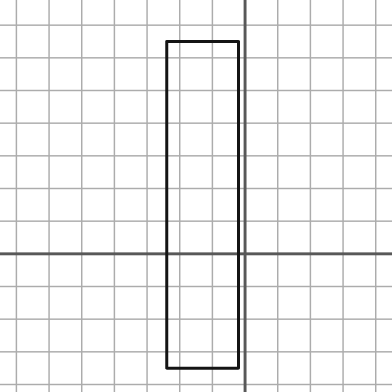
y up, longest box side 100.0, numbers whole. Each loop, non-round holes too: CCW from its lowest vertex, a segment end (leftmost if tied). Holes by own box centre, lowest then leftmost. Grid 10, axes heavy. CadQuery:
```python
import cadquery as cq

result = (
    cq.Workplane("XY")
    .moveTo(-24.0, -35.0)
    .lineTo(-2.0, -35.0)
    .lineTo(-2.0, 65.0)
    .lineTo(-24.0, 65.0)
    .close()
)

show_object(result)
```